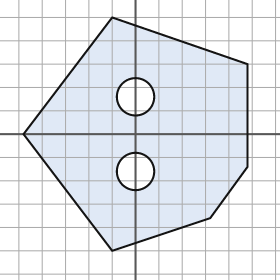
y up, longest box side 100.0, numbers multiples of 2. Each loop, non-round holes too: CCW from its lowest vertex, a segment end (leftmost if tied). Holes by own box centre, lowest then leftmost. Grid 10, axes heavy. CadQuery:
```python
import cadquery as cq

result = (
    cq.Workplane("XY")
    .moveTo(-10.0, -50.0)
    .lineTo(32.0, -36.0)
    .lineTo(48.0, -14.0)
    .lineTo(48.0, 30.0)
    .lineTo(-10.0, 50.0)
    .lineTo(-48.0, 0.0)
    .close()
    .moveTo(0.0, -16.0)
    .circle(8.0)
    .moveTo(0.0, 16.0)
    .circle(8.0)
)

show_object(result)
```